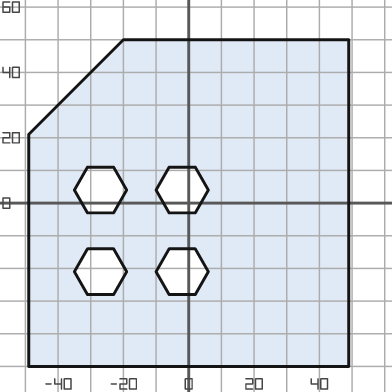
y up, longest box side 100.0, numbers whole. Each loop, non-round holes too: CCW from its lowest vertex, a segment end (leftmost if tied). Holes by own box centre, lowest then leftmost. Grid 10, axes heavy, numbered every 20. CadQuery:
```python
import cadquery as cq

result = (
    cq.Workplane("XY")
    .moveTo(-49.0, -50.0)
    .lineTo(49.0, -50.0)
    .lineTo(49.0, 50.0)
    .lineTo(-20.0, 50.0)
    .lineTo(-49.0, 21.0)
    .close()
    .moveTo(-31.0, -28.0)
    .lineTo(-23.0, -28.0)
    .lineTo(-19.0, -21.0)
    .lineTo(-23.0, -14.0)
    .lineTo(-31.0, -14.0)
    .lineTo(-35.0, -21.0)
    .close()
    .moveTo(-6.0, -28.0)
    .lineTo(2.0, -28.0)
    .lineTo(6.0, -21.0)
    .lineTo(2.0, -14.0)
    .lineTo(-6.0, -14.0)
    .lineTo(-10.0, -21.0)
    .close()
    .moveTo(-31.0, -3.0)
    .lineTo(-23.0, -3.0)
    .lineTo(-19.0, 4.0)
    .lineTo(-23.0, 11.0)
    .lineTo(-31.0, 11.0)
    .lineTo(-35.0, 4.0)
    .close()
    .moveTo(-6.0, -3.0)
    .lineTo(2.0, -3.0)
    .lineTo(6.0, 4.0)
    .lineTo(2.0, 11.0)
    .lineTo(-6.0, 11.0)
    .lineTo(-10.0, 4.0)
    .close()
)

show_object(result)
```